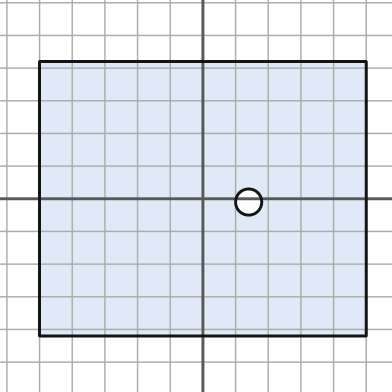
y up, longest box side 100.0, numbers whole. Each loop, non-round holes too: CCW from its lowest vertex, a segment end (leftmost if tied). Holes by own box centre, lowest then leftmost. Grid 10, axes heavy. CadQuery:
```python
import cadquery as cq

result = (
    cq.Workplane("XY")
    .moveTo(-50.0, -42.0)
    .lineTo(50.0, -42.0)
    .lineTo(50.0, 42.0)
    .lineTo(-50.0, 42.0)
    .close()
    .moveTo(14.0, -1.0)
    .circle(4.0)
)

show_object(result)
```